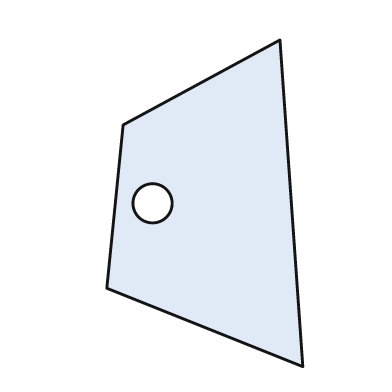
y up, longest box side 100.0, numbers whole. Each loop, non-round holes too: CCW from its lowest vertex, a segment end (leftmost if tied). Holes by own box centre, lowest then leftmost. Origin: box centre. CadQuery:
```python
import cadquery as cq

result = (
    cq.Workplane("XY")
    .moveTo(30.0, -50.0)
    .lineTo(23.0, 50.0)
    .lineTo(-25.0, 24.0)
    .lineTo(-30.0, -26.0)
    .close()
    .moveTo(-16.0, 0.0)
    .circle(6.0)
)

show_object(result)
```